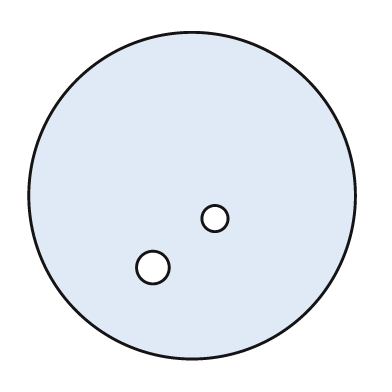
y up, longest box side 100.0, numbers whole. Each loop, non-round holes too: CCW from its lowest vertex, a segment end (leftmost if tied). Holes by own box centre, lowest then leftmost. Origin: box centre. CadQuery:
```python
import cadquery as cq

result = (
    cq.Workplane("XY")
    .moveTo(0.0, 0.0)
    .circle(50.0)
    .moveTo(-12.0, -22.0)
    .circle(5.0)
    .moveTo(7.0, -7.0)
    .circle(4.0)
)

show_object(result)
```